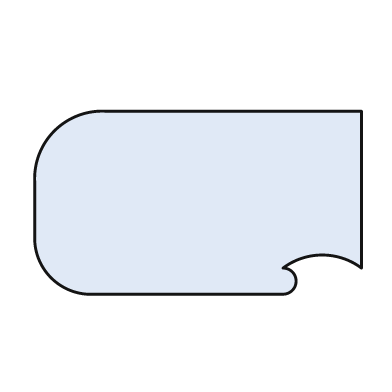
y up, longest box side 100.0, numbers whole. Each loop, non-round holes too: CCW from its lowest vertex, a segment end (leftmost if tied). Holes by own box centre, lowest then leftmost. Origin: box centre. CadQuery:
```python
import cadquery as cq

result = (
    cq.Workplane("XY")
    .moveTo(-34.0, -28.0)
    .lineTo(26.0, -28.0)
    .threePointArc((30.0, -24.0), (26.0, -20.0))
    .threePointArc((38.0, -16.0), (50.0, -20.0))
    .lineTo(50.0, 28.0)
    .lineTo(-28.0, 28.0)
    .threePointArc((-44.0, 22.0), (-50.0, 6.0))
    .lineTo(-50.0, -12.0)
    .threePointArc((-45.0, -23.0), (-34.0, -28.0))
    .close()
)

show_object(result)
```